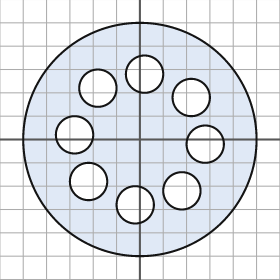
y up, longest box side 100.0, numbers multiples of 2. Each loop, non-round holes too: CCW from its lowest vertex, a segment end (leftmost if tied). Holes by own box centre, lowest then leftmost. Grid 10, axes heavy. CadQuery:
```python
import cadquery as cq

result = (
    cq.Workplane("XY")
    .moveTo(0.0, 0.0)
    .circle(50.0)
    .moveTo(-2.0, -28.0)
    .circle(8.0)
    .moveTo(18.0, -22.0)
    .circle(8.0)
    .moveTo(-22.0, -18.0)
    .circle(8.0)
    .moveTo(28.0, -2.0)
    .circle(8.0)
    .moveTo(-28.0, 2.0)
    .circle(8.0)
    .moveTo(22.0, 18.0)
    .circle(8.0)
    .moveTo(-18.0, 22.0)
    .circle(8.0)
    .moveTo(2.0, 28.0)
    .circle(8.0)
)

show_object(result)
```